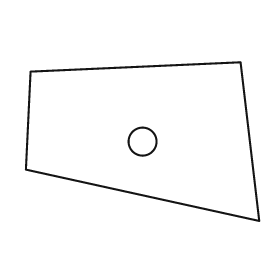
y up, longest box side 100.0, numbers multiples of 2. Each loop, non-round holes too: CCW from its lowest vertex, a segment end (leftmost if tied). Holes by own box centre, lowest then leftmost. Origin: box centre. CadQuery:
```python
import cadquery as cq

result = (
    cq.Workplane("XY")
    .moveTo(50.0, -34.0)
    .lineTo(42.0, 34.0)
    .lineTo(-48.0, 30.0)
    .lineTo(-50.0, -12.0)
    .close()
    .moveTo(0.0, 0.0)
    .circle(6.0)
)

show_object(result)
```